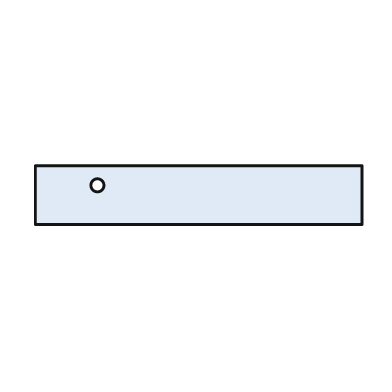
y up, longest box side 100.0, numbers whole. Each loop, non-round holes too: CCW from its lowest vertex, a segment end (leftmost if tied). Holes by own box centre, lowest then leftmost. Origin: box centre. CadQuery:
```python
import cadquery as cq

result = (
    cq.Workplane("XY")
    .moveTo(-50.0, -9.0)
    .lineTo(50.0, -9.0)
    .lineTo(50.0, 9.0)
    .lineTo(-50.0, 9.0)
    .close()
    .moveTo(-31.0, 3.0)
    .circle(2.0)
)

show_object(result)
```